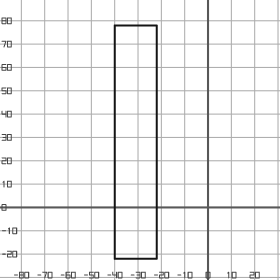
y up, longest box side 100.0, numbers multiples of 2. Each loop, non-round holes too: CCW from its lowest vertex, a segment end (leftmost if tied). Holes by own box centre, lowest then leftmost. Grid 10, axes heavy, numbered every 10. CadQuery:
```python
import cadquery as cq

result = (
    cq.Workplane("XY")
    .moveTo(-40.0, -22.0)
    .lineTo(-22.0, -22.0)
    .lineTo(-22.0, 78.0)
    .lineTo(-40.0, 78.0)
    .close()
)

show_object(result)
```